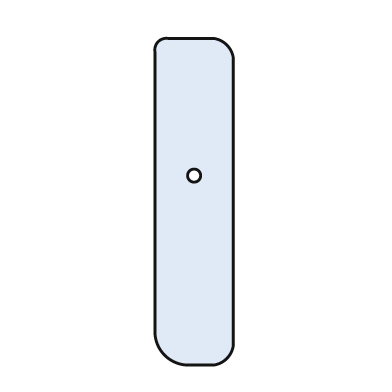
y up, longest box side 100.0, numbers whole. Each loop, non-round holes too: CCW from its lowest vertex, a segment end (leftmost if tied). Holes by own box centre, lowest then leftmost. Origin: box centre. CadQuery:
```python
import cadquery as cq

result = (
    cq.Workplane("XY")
    .moveTo(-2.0, -50.0)
    .lineTo(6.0, -50.0)
    .threePointArc((10.0, -48.0), (12.0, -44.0))
    .lineTo(12.0, 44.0)
    .threePointArc((10.0, 48.0), (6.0, 50.0))
    .lineTo(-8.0, 50.0)
    .threePointArc((-11.0, 49.0), (-12.0, 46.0))
    .lineTo(-12.0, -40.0)
    .threePointArc((-9.0, -47.0), (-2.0, -50.0))
    .close()
    .moveTo(0.0, 8.0)
    .circle(2.0)
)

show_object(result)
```